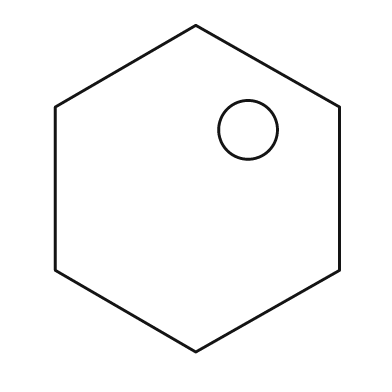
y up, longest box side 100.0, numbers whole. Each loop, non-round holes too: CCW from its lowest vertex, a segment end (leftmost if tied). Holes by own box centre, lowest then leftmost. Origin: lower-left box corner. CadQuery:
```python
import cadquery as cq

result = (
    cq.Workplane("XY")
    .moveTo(43.0, 0.0)
    .lineTo(87.0, 25.0)
    .lineTo(87.0, 75.0)
    .lineTo(43.0, 100.0)
    .lineTo(0.0, 75.0)
    .lineTo(0.0, 25.0)
    .close()
    .moveTo(59.0, 68.0)
    .circle(9.0)
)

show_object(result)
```